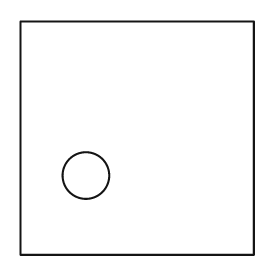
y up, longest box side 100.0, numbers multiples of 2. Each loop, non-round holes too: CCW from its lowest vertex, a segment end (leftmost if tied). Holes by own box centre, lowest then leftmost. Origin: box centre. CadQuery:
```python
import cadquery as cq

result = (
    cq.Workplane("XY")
    .moveTo(-50.0, -50.0)
    .lineTo(50.0, -50.0)
    .lineTo(50.0, 50.0)
    .lineTo(-50.0, 50.0)
    .close()
    .moveTo(-22.0, -16.0)
    .circle(10.0)
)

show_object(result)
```